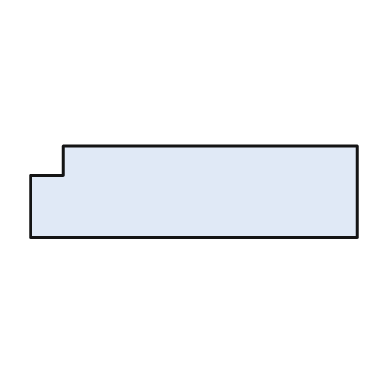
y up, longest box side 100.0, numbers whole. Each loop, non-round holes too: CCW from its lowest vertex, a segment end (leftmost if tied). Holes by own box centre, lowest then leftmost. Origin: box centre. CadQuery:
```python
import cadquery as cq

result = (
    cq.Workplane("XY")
    .moveTo(-50.0, -14.0)
    .lineTo(50.0, -14.0)
    .lineTo(50.0, 14.0)
    .lineTo(-40.0, 14.0)
    .lineTo(-40.0, 5.0)
    .lineTo(-50.0, 5.0)
    .close()
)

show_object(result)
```